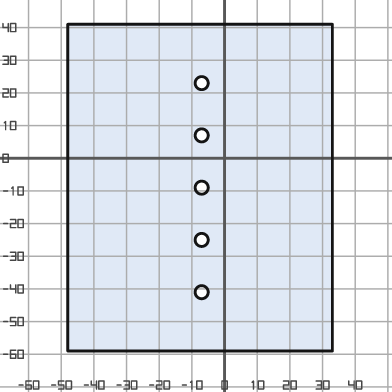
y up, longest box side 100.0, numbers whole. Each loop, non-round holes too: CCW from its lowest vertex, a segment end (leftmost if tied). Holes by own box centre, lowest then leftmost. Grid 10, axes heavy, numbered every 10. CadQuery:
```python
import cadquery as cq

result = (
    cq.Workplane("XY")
    .moveTo(-48.0, -59.0)
    .lineTo(33.0, -59.0)
    .lineTo(33.0, 41.0)
    .lineTo(-48.0, 41.0)
    .close()
    .moveTo(-7.0, -41.0)
    .circle(2.0)
    .moveTo(-7.0, -25.0)
    .circle(2.0)
    .moveTo(-7.0, -9.0)
    .circle(2.0)
    .moveTo(-7.0, 7.0)
    .circle(2.0)
    .moveTo(-7.0, 23.0)
    .circle(2.0)
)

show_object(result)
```